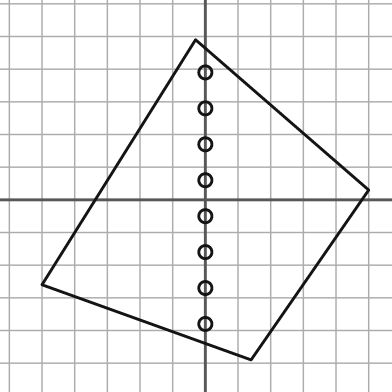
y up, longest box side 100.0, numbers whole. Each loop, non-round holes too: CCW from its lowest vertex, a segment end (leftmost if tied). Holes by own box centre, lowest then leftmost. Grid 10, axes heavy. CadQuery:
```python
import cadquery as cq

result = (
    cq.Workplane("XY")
    .moveTo(14.0, -49.0)
    .lineTo(50.0, 3.0)
    .lineTo(-3.0, 49.0)
    .lineTo(-50.0, -26.0)
    .close()
    .moveTo(0.0, -38.0)
    .circle(2.0)
    .moveTo(0.0, -27.0)
    .circle(2.0)
    .moveTo(0.0, -16.0)
    .circle(2.0)
    .moveTo(0.0, -5.0)
    .circle(2.0)
    .moveTo(0.0, 6.0)
    .circle(2.0)
    .moveTo(0.0, 17.0)
    .circle(2.0)
    .moveTo(0.0, 28.0)
    .circle(2.0)
    .moveTo(0.0, 39.0)
    .circle(2.0)
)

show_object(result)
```